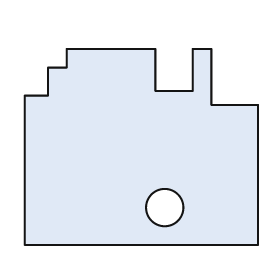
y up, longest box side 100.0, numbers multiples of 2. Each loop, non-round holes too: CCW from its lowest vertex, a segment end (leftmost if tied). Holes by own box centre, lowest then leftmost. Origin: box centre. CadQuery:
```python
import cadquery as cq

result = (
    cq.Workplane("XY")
    .moveTo(-50.0, -42.0)
    .lineTo(50.0, -42.0)
    .lineTo(50.0, 18.0)
    .lineTo(30.0, 18.0)
    .lineTo(30.0, 42.0)
    .lineTo(22.0, 42.0)
    .lineTo(22.0, 24.0)
    .lineTo(6.0, 24.0)
    .lineTo(6.0, 42.0)
    .lineTo(-32.0, 42.0)
    .lineTo(-32.0, 34.0)
    .lineTo(-40.0, 34.0)
    .lineTo(-40.0, 22.0)
    .lineTo(-50.0, 22.0)
    .close()
    .moveTo(10.0, -26.0)
    .circle(8.0)
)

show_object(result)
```